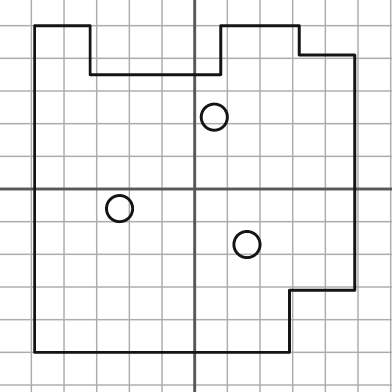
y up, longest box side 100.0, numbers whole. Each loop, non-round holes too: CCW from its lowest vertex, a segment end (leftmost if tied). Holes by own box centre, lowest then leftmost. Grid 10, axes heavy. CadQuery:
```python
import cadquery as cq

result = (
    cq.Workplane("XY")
    .moveTo(-49.0, -50.0)
    .lineTo(29.0, -50.0)
    .lineTo(29.0, -31.0)
    .lineTo(49.0, -31.0)
    .lineTo(49.0, 41.0)
    .lineTo(32.0, 41.0)
    .lineTo(32.0, 50.0)
    .lineTo(8.0, 50.0)
    .lineTo(8.0, 35.0)
    .lineTo(-32.0, 35.0)
    .lineTo(-32.0, 50.0)
    .lineTo(-49.0, 50.0)
    .close()
    .moveTo(16.0, -17.0)
    .circle(4.0)
    .moveTo(-23.0, -6.0)
    .circle(4.0)
    .moveTo(6.0, 22.0)
    .circle(4.0)
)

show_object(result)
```